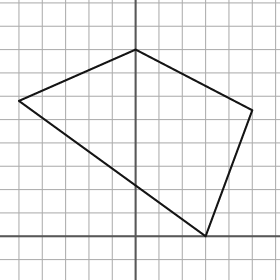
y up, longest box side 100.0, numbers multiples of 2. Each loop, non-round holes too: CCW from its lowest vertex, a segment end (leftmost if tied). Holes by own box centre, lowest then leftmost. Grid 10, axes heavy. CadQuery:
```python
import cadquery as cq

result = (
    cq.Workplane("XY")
    .moveTo(30.0, 0.0)
    .lineTo(50.0, 54.0)
    .lineTo(0.0, 80.0)
    .lineTo(-50.0, 58.0)
    .close()
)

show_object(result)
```